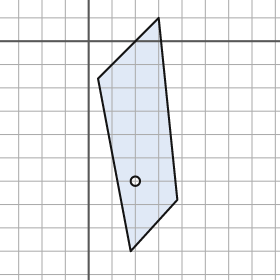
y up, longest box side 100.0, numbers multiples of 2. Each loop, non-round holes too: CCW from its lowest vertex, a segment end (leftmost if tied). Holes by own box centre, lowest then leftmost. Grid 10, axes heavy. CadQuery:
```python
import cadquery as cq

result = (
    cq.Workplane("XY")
    .moveTo(18.0, -90.0)
    .lineTo(38.0, -68.0)
    .lineTo(30.0, 10.0)
    .lineTo(4.0, -16.0)
    .close()
    .moveTo(20.0, -60.0)
    .circle(2.0)
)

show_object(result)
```